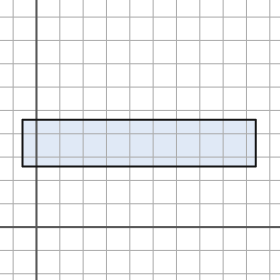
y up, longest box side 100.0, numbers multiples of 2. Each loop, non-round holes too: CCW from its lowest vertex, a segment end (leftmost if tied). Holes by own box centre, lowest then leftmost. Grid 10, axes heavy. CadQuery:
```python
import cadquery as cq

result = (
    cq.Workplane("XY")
    .moveTo(-6.0, 26.0)
    .lineTo(94.0, 26.0)
    .lineTo(94.0, 46.0)
    .lineTo(-6.0, 46.0)
    .close()
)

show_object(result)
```